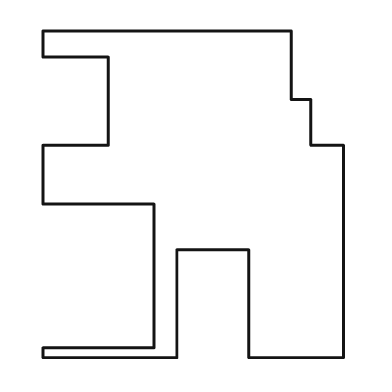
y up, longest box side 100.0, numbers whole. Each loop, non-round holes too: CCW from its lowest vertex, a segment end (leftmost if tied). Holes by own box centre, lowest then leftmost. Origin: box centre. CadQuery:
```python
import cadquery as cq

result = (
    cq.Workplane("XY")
    .moveTo(-46.0, -50.0)
    .lineTo(-5.0, -50.0)
    .lineTo(-5.0, -17.0)
    .lineTo(17.0, -17.0)
    .lineTo(17.0, -50.0)
    .lineTo(46.0, -50.0)
    .lineTo(46.0, 15.0)
    .lineTo(36.0, 15.0)
    .lineTo(36.0, 29.0)
    .lineTo(30.0, 29.0)
    .lineTo(30.0, 50.0)
    .lineTo(-46.0, 50.0)
    .lineTo(-46.0, 42.0)
    .lineTo(-26.0, 42.0)
    .lineTo(-26.0, 15.0)
    .lineTo(-46.0, 15.0)
    .lineTo(-46.0, -3.0)
    .lineTo(-12.0, -3.0)
    .lineTo(-12.0, -47.0)
    .lineTo(-46.0, -47.0)
    .close()
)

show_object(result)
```